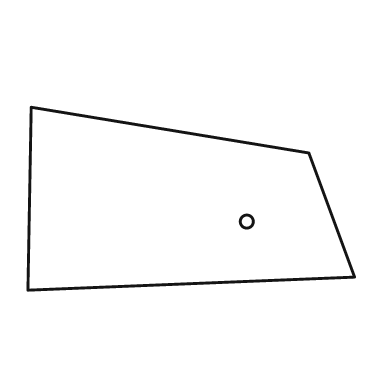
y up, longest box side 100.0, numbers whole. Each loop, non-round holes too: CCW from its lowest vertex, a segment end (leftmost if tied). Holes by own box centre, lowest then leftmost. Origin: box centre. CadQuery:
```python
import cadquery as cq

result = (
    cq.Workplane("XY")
    .moveTo(-50.0, -28.0)
    .lineTo(50.0, -24.0)
    .lineTo(36.0, 14.0)
    .lineTo(-49.0, 28.0)
    .close()
    .moveTo(17.0, -7.0)
    .circle(2.0)
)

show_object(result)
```